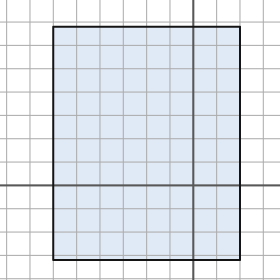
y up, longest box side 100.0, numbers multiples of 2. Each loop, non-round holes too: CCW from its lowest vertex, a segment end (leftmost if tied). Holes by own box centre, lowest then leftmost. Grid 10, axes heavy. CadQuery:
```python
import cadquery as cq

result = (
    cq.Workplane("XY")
    .moveTo(-60.0, -32.0)
    .lineTo(20.0, -32.0)
    .lineTo(20.0, 68.0)
    .lineTo(-60.0, 68.0)
    .close()
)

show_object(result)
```